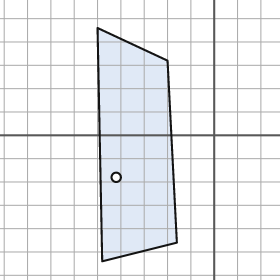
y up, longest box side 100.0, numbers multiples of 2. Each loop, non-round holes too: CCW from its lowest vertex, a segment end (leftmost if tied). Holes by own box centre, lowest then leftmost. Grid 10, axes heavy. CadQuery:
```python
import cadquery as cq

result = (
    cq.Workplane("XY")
    .moveTo(-48.0, -54.0)
    .lineTo(-16.0, -46.0)
    .lineTo(-20.0, 32.0)
    .lineTo(-50.0, 46.0)
    .close()
    .moveTo(-42.0, -18.0)
    .circle(2.0)
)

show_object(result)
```